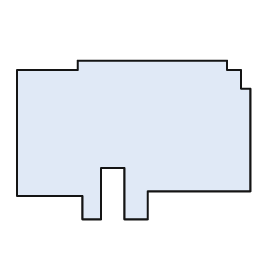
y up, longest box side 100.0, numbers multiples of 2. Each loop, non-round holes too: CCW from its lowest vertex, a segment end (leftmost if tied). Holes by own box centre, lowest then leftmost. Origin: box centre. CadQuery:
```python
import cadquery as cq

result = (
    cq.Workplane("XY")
    .moveTo(-22.0, -34.0)
    .lineTo(-14.0, -34.0)
    .lineTo(-14.0, -12.0)
    .lineTo(-4.0, -12.0)
    .lineTo(-4.0, -34.0)
    .lineTo(6.0, -34.0)
    .lineTo(6.0, -22.0)
    .lineTo(50.0, -22.0)
    .lineTo(50.0, 22.0)
    .lineTo(46.0, 22.0)
    .lineTo(46.0, 30.0)
    .lineTo(40.0, 30.0)
    .lineTo(40.0, 34.0)
    .lineTo(-24.0, 34.0)
    .lineTo(-24.0, 30.0)
    .lineTo(-50.0, 30.0)
    .lineTo(-50.0, -24.0)
    .lineTo(-22.0, -24.0)
    .close()
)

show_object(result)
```